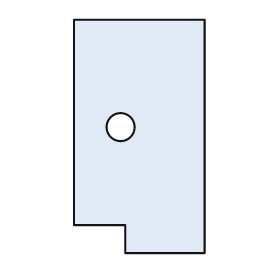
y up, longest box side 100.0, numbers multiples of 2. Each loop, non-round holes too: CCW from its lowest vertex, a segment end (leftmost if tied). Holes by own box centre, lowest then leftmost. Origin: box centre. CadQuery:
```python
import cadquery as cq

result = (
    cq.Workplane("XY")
    .moveTo(-6.0, -50.0)
    .lineTo(28.0, -50.0)
    .lineTo(28.0, 50.0)
    .lineTo(-28.0, 50.0)
    .lineTo(-28.0, -38.0)
    .lineTo(-6.0, -38.0)
    .close()
    .moveTo(-8.0, 4.0)
    .circle(6.0)
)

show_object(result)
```